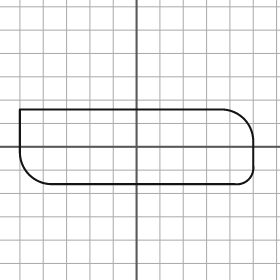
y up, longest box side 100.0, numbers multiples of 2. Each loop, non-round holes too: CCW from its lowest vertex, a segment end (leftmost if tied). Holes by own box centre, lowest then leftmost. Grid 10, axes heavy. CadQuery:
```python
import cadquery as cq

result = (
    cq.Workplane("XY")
    .moveTo(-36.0, -16.0)
    .lineTo(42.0, -16.0)
    .threePointArc((48.0, -14.0), (50.0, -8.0))
    .lineTo(50.0, 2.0)
    .threePointArc((46.0, 12.0), (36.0, 16.0))
    .lineTo(-50.0, 16.0)
    .lineTo(-50.0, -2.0)
    .threePointArc((-46.0, -12.0), (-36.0, -16.0))
    .close()
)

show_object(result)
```